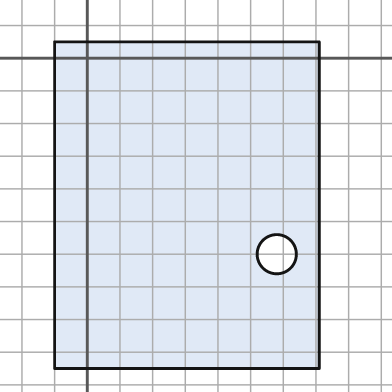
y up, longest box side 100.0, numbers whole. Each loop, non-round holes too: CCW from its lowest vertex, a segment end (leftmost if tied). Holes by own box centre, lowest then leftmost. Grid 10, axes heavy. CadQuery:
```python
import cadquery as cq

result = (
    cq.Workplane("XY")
    .moveTo(-10.0, -95.0)
    .lineTo(71.0, -95.0)
    .lineTo(71.0, 5.0)
    .lineTo(-10.0, 5.0)
    .close()
    .moveTo(58.0, -60.0)
    .circle(6.0)
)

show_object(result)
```